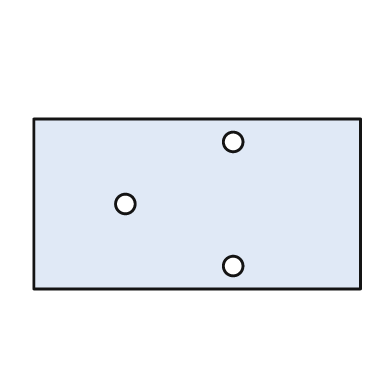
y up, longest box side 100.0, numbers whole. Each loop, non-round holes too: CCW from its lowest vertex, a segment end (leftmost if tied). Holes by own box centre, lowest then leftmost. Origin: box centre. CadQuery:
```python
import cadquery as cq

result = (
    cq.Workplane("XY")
    .moveTo(-50.0, -26.0)
    .lineTo(50.0, -26.0)
    .lineTo(50.0, 26.0)
    .lineTo(-50.0, 26.0)
    .close()
    .moveTo(11.0, -19.0)
    .circle(3.0)
    .moveTo(-22.0, 0.0)
    .circle(3.0)
    .moveTo(11.0, 19.0)
    .circle(3.0)
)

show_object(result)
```